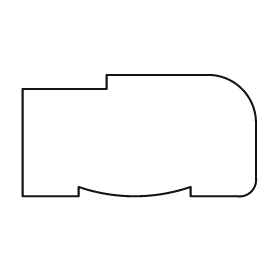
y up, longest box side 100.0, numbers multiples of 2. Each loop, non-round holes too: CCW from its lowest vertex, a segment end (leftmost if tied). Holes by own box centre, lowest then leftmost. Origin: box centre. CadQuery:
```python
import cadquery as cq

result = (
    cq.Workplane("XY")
    .moveTo(-50.0, -26.0)
    .lineTo(-26.0, -26.0)
    .lineTo(-26.0, -22.0)
    .threePointArc((-2.0, -26.0), (22.0, -22.0))
    .lineTo(22.0, -26.0)
    .lineTo(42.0, -26.0)
    .threePointArc((48.0, -24.0), (50.0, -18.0))
    .lineTo(50.0, 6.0)
    .threePointArc((44.0, 20.0), (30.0, 26.0))
    .lineTo(-14.0, 26.0)
    .lineTo(-14.0, 20.0)
    .lineTo(-50.0, 20.0)
    .close()
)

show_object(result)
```